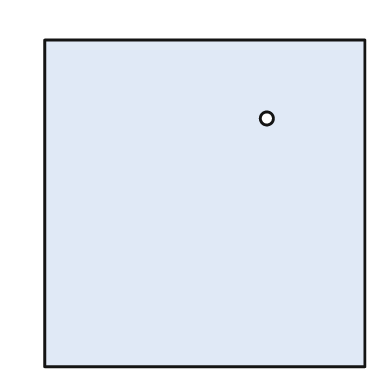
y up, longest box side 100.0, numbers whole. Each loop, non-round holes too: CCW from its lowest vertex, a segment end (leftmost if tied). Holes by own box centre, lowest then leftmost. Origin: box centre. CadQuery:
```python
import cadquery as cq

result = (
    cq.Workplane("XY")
    .moveTo(-49.0, -50.0)
    .lineTo(49.0, -50.0)
    .lineTo(49.0, 50.0)
    .lineTo(-49.0, 50.0)
    .close()
    .moveTo(19.0, 26.0)
    .circle(2.0)
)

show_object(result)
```